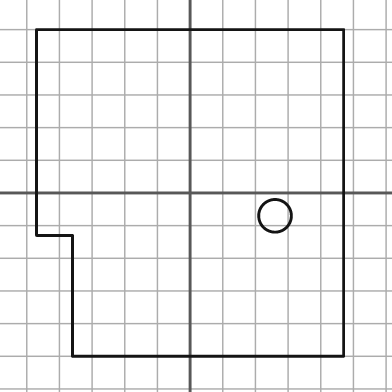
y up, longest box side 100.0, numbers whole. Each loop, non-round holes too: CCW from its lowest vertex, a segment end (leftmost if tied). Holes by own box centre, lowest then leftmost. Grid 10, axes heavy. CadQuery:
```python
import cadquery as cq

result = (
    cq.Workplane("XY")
    .moveTo(-36.0, -50.0)
    .lineTo(47.0, -50.0)
    .lineTo(47.0, 50.0)
    .lineTo(-47.0, 50.0)
    .lineTo(-47.0, -13.0)
    .lineTo(-36.0, -13.0)
    .close()
    .moveTo(26.0, -7.0)
    .circle(5.0)
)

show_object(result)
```